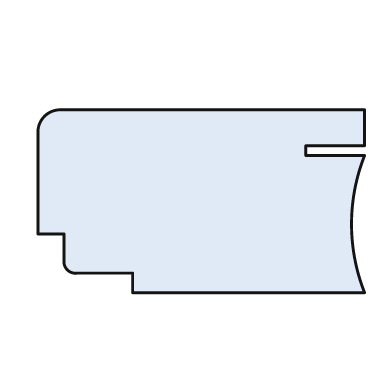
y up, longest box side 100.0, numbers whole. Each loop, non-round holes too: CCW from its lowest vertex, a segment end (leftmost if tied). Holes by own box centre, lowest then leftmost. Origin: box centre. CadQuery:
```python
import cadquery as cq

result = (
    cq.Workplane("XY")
    .moveTo(-21.0, -28.0)
    .lineTo(50.0, -28.0)
    .threePointArc((46.0, -7.0), (50.0, 14.0))
    .lineTo(32.0, 14.0)
    .lineTo(32.0, 17.0)
    .lineTo(50.0, 17.0)
    .lineTo(50.0, 28.0)
    .lineTo(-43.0, 28.0)
    .threePointArc((-48.0, 26.0), (-50.0, 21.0))
    .lineTo(-50.0, -10.0)
    .lineTo(-42.0, -10.0)
    .lineTo(-42.0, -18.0)
    .threePointArc((-41.0, -21.0), (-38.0, -22.0))
    .lineTo(-21.0, -22.0)
    .close()
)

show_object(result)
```